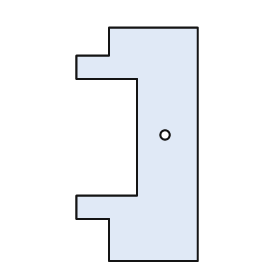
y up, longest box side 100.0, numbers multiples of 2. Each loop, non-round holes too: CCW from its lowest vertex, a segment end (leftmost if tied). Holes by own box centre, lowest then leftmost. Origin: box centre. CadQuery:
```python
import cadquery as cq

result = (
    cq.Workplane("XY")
    .moveTo(-12.0, -50.0)
    .lineTo(26.0, -50.0)
    .lineTo(26.0, 50.0)
    .lineTo(-12.0, 50.0)
    .lineTo(-12.0, 38.0)
    .lineTo(-26.0, 38.0)
    .lineTo(-26.0, 28.0)
    .lineTo(0.0, 28.0)
    .lineTo(0.0, -22.0)
    .lineTo(-26.0, -22.0)
    .lineTo(-26.0, -32.0)
    .lineTo(-12.0, -32.0)
    .close()
    .moveTo(12.0, 4.0)
    .circle(2.0)
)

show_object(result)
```